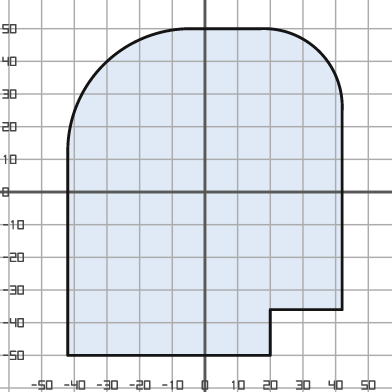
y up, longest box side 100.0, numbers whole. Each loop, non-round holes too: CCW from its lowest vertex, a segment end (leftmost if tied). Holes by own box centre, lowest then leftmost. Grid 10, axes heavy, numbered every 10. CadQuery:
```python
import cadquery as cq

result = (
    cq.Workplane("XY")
    .moveTo(-42.0, -50.0)
    .lineTo(20.0, -50.0)
    .lineTo(20.0, -36.0)
    .lineTo(42.0, -36.0)
    .lineTo(42.0, 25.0)
    .threePointArc((35.0, 43.0), (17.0, 50.0))
    .lineTo(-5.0, 50.0)
    .threePointArc((-31.0, 39.0), (-42.0, 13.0))
    .close()
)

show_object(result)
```